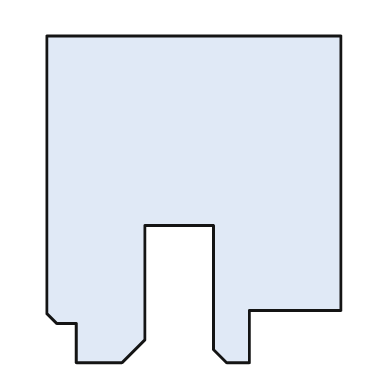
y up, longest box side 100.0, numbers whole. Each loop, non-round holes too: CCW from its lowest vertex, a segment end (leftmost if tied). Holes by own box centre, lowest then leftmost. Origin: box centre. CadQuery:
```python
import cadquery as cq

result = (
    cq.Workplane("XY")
    .moveTo(-36.0, -50.0)
    .lineTo(-22.0, -50.0)
    .lineTo(-15.0, -43.0)
    .lineTo(-15.0, -8.0)
    .lineTo(6.0, -8.0)
    .lineTo(6.0, -46.0)
    .lineTo(10.0, -50.0)
    .lineTo(17.0, -50.0)
    .lineTo(17.0, -34.0)
    .lineTo(45.0, -34.0)
    .lineTo(45.0, 50.0)
    .lineTo(-45.0, 50.0)
    .lineTo(-45.0, -35.0)
    .lineTo(-42.0, -38.0)
    .lineTo(-36.0, -38.0)
    .close()
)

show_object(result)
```